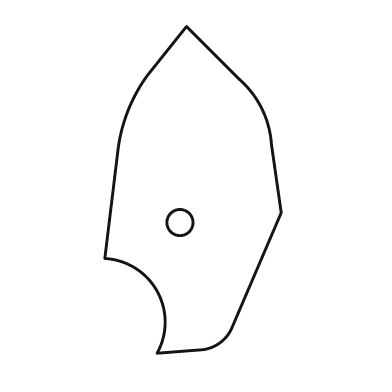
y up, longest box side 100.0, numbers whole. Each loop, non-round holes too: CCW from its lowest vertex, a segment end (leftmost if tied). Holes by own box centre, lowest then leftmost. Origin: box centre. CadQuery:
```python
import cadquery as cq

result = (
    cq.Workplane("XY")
    .moveTo(-11.0, -50.0)
    .lineTo(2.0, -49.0)
    .threePointArc((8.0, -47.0), (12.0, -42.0))
    .lineTo(27.0, -7.0)
    .lineTo(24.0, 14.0)
    .threePointArc((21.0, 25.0), (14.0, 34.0))
    .lineTo(-2.0, 50.0)
    .lineTo(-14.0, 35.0)
    .threePointArc((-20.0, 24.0), (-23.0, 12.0))
    .lineTo(-27.0, -21.0)
    .threePointArc((-11.0, -31.0), (-11.0, -50.0))
    .close()
    .moveTo(-4.0, -10.0)
    .circle(4.0)
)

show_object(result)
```